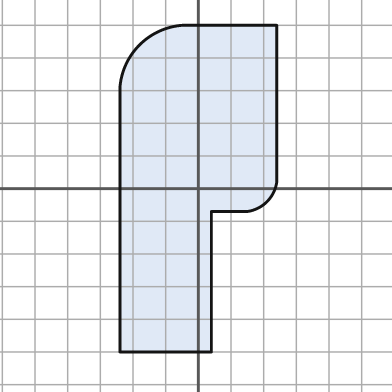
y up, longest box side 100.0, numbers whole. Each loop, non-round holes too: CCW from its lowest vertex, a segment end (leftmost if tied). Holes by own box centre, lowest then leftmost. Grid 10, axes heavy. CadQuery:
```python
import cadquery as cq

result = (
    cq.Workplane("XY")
    .moveTo(-24.0, -50.0)
    .lineTo(4.0, -50.0)
    .lineTo(4.0, -7.0)
    .lineTo(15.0, -7.0)
    .threePointArc((21.0, -4.0), (24.0, 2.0))
    .lineTo(24.0, 50.0)
    .lineTo(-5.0, 50.0)
    .threePointArc((-18.0, 44.0), (-24.0, 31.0))
    .close()
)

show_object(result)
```